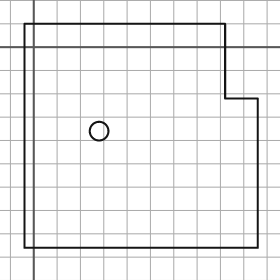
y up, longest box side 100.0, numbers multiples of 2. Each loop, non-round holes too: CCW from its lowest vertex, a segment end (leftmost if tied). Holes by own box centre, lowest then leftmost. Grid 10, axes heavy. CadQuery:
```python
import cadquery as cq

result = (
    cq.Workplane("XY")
    .moveTo(-4.0, -86.0)
    .lineTo(96.0, -86.0)
    .lineTo(96.0, -22.0)
    .lineTo(82.0, -22.0)
    .lineTo(82.0, 10.0)
    .lineTo(-4.0, 10.0)
    .close()
    .moveTo(28.0, -36.0)
    .circle(4.0)
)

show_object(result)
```